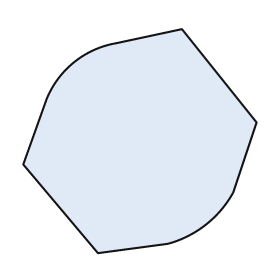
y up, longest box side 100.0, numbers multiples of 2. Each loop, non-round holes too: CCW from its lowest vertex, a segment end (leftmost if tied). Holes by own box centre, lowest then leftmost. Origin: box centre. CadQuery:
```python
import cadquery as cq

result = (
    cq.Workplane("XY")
    .moveTo(-18.0, -48.0)
    .lineTo(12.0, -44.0)
    .threePointArc((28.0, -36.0), (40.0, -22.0))
    .lineTo(50.0, 8.0)
    .lineTo(18.0, 48.0)
    .lineTo(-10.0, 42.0)
    .threePointArc((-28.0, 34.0), (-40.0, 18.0))
    .lineTo(-50.0, -10.0)
    .close()
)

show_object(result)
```